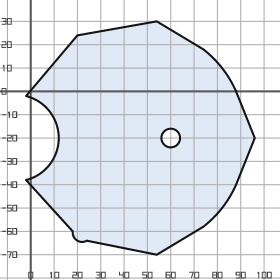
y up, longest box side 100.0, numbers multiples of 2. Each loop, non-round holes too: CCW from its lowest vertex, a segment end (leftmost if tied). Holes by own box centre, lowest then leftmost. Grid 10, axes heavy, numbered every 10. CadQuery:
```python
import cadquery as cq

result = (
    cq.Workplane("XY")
    .moveTo(54.0, -70.0)
    .lineTo(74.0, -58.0)
    .threePointArc((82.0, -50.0), (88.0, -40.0))
    .lineTo(96.0, -20.0)
    .lineTo(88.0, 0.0)
    .threePointArc((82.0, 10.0), (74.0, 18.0))
    .lineTo(54.0, 30.0)
    .lineTo(20.0, 24.0)
    .lineTo(-2.0, -2.0)
    .threePointArc((12.0, -20.0), (-2.0, -38.0))
    .lineTo(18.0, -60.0)
    .threePointArc((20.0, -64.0), (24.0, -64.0))
    .close()
    .moveTo(60.0, -20.0)
    .circle(4.0)
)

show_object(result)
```